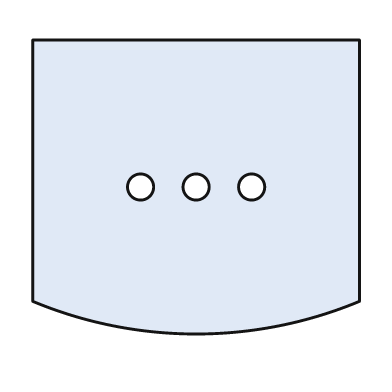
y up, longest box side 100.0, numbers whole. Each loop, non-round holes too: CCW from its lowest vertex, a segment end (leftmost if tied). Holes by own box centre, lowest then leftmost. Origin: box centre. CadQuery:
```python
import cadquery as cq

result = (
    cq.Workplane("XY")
    .moveTo(-50.0, -35.0)
    .threePointArc((0.0, -45.0), (50.0, -35.0))
    .lineTo(50.0, 45.0)
    .lineTo(-50.0, 45.0)
    .close()
    .moveTo(-17.0, 0.0)
    .circle(4.0)
    .moveTo(0.0, 0.0)
    .circle(4.0)
    .moveTo(17.0, 0.0)
    .circle(4.0)
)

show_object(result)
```